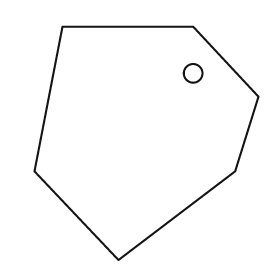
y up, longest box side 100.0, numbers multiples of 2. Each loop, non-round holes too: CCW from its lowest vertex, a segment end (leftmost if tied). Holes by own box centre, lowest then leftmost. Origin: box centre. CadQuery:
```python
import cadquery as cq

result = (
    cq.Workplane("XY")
    .moveTo(-12.0, -50.0)
    .lineTo(38.0, -12.0)
    .lineTo(48.0, 20.0)
    .lineTo(20.0, 50.0)
    .lineTo(-36.0, 50.0)
    .lineTo(-48.0, -12.0)
    .close()
    .moveTo(20.0, 30.0)
    .circle(4.0)
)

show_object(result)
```